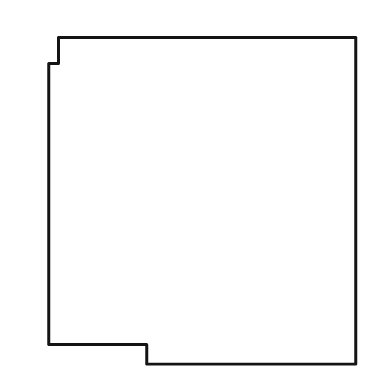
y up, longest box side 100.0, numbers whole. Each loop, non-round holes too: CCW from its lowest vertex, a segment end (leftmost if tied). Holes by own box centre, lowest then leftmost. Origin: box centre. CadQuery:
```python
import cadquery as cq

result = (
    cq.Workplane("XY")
    .moveTo(-17.0, -50.0)
    .lineTo(47.0, -50.0)
    .lineTo(47.0, 50.0)
    .lineTo(-44.0, 50.0)
    .lineTo(-44.0, 42.0)
    .lineTo(-47.0, 42.0)
    .lineTo(-47.0, -44.0)
    .lineTo(-17.0, -44.0)
    .close()
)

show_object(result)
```